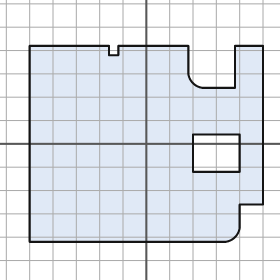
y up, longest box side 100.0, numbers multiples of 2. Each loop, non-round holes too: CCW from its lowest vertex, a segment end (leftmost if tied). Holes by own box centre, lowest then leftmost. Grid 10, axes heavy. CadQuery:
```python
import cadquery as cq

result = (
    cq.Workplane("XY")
    .moveTo(-50.0, -42.0)
    .lineTo(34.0, -42.0)
    .threePointArc((38.0, -40.0), (40.0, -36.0))
    .lineTo(40.0, -26.0)
    .lineTo(50.0, -26.0)
    .lineTo(50.0, 42.0)
    .lineTo(38.0, 42.0)
    .lineTo(38.0, 24.0)
    .lineTo(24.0, 24.0)
    .threePointArc((20.0, 26.0), (18.0, 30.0))
    .lineTo(18.0, 42.0)
    .lineTo(-12.0, 42.0)
    .lineTo(-12.0, 38.0)
    .lineTo(-16.0, 38.0)
    .lineTo(-16.0, 42.0)
    .lineTo(-50.0, 42.0)
    .close()
    .moveTo(20.0, -12.0)
    .lineTo(40.0, -12.0)
    .lineTo(40.0, 4.0)
    .lineTo(20.0, 4.0)
    .close()
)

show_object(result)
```